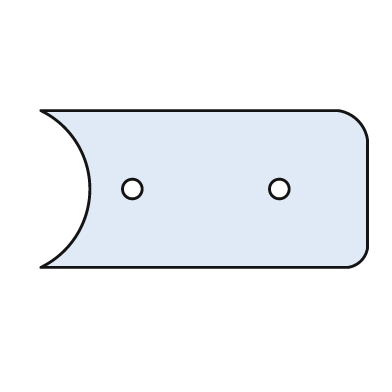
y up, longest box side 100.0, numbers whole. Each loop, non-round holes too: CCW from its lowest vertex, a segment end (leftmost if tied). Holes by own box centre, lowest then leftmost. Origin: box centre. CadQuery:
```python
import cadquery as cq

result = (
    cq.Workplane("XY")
    .moveTo(-50.0, -24.0)
    .lineTo(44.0, -24.0)
    .threePointArc((48.0, -22.0), (50.0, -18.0))
    .lineTo(50.0, 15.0)
    .threePointArc((47.0, 21.0), (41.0, 24.0))
    .lineTo(-50.0, 24.0)
    .threePointArc((-35.0, 0.0), (-50.0, -24.0))
    .close()
    .moveTo(-22.0, 0.0)
    .circle(3.0)
    .moveTo(23.0, 0.0)
    .circle(3.0)
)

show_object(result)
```